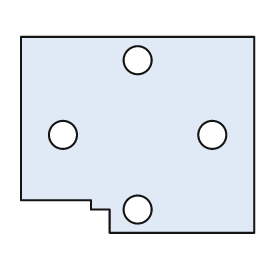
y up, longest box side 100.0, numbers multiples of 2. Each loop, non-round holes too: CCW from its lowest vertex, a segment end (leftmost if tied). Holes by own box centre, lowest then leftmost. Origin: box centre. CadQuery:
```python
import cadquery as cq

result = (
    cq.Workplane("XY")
    .moveTo(-12.0, -42.0)
    .lineTo(50.0, -42.0)
    .lineTo(50.0, 42.0)
    .lineTo(-50.0, 42.0)
    .lineTo(-50.0, -28.0)
    .lineTo(-20.0, -28.0)
    .lineTo(-20.0, -32.0)
    .lineTo(-12.0, -32.0)
    .close()
    .moveTo(0.0, -32.0)
    .circle(6.0)
    .moveTo(-32.0, 0.0)
    .circle(6.0)
    .moveTo(32.0, 0.0)
    .circle(6.0)
    .moveTo(0.0, 32.0)
    .circle(6.0)
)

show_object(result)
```